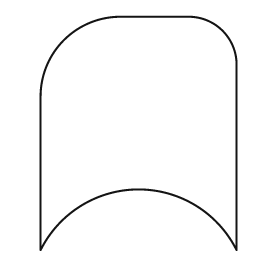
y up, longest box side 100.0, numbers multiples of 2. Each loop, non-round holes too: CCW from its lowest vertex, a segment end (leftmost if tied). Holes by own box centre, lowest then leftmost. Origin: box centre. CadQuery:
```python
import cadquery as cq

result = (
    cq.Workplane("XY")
    .moveTo(-42.0, -50.0)
    .threePointArc((0.0, -24.0), (42.0, -50.0))
    .lineTo(42.0, 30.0)
    .threePointArc((36.0, 44.0), (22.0, 50.0))
    .lineTo(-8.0, 50.0)
    .threePointArc((-32.0, 40.0), (-42.0, 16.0))
    .close()
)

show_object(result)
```